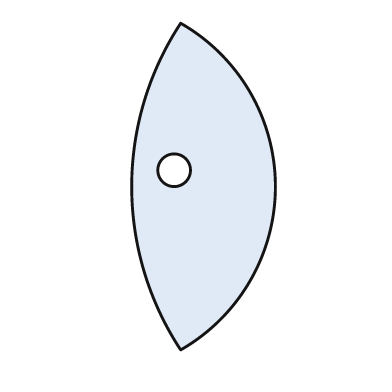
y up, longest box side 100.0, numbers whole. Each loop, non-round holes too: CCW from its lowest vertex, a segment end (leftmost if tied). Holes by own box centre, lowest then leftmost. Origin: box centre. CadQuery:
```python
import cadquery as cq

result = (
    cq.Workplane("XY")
    .moveTo(-7.0, -50.0)
    .threePointArc((22.0, 0.0), (-7.0, 50.0))
    .threePointArc((-22.0, 0.0), (-7.0, -50.0))
    .close()
    .moveTo(-9.0, 5.0)
    .circle(5.0)
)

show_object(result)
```